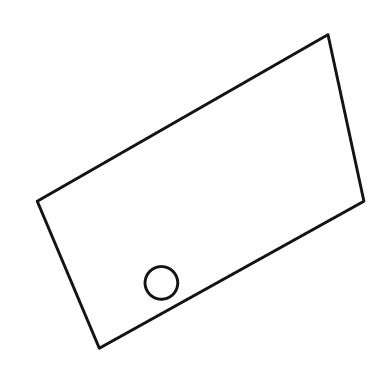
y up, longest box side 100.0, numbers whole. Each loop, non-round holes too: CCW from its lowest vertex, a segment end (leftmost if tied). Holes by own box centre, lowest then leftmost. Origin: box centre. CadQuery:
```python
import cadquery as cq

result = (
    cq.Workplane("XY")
    .moveTo(-31.0, -48.0)
    .lineTo(50.0, -3.0)
    .lineTo(39.0, 48.0)
    .lineTo(-50.0, -3.0)
    .close()
    .moveTo(-12.0, -28.0)
    .circle(5.0)
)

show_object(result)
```